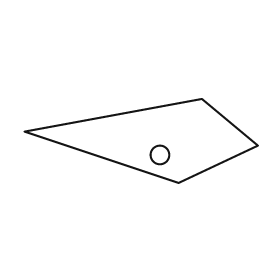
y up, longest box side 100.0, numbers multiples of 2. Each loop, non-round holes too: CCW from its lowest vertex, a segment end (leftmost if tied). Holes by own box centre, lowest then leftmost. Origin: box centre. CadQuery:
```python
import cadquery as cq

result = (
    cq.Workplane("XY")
    .moveTo(16.0, -18.0)
    .lineTo(50.0, -2.0)
    .lineTo(26.0, 18.0)
    .lineTo(-50.0, 4.0)
    .close()
    .moveTo(8.0, -6.0)
    .circle(4.0)
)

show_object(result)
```